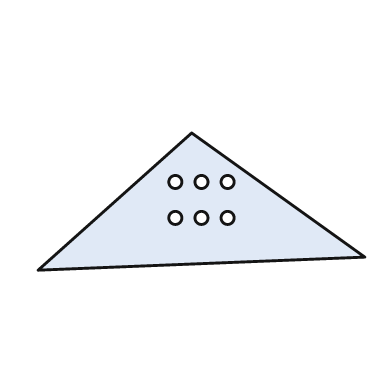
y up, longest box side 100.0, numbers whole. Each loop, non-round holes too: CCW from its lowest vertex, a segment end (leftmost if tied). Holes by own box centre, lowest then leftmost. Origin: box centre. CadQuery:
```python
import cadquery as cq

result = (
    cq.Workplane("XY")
    .moveTo(-50.0, -21.0)
    .lineTo(50.0, -17.0)
    .lineTo(-3.0, 21.0)
    .close()
    .moveTo(-8.0, -5.0)
    .circle(2.0)
    .moveTo(0.0, -5.0)
    .circle(2.0)
    .moveTo(8.0, -5.0)
    .circle(2.0)
    .moveTo(-8.0, 6.0)
    .circle(2.0)
    .moveTo(0.0, 6.0)
    .circle(2.0)
    .moveTo(8.0, 6.0)
    .circle(2.0)
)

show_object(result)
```